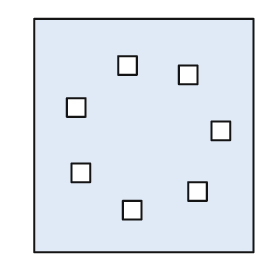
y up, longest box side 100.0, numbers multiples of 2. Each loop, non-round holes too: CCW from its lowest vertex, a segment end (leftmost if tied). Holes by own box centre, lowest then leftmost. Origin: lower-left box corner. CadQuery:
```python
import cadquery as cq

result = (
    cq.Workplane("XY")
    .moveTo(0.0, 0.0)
    .lineTo(94.0, 0.0)
    .lineTo(94.0, 100.0)
    .lineTo(0.0, 100.0)
    .close()
    .moveTo(38.0, 14.0)
    .lineTo(46.0, 14.0)
    .lineTo(46.0, 22.0)
    .lineTo(38.0, 22.0)
    .close()
    .moveTo(66.0, 22.0)
    .lineTo(74.0, 22.0)
    .lineTo(74.0, 30.0)
    .lineTo(66.0, 30.0)
    .close()
    .moveTo(16.0, 30.0)
    .lineTo(24.0, 30.0)
    .lineTo(24.0, 38.0)
    .lineTo(16.0, 38.0)
    .close()
    .moveTo(76.0, 48.0)
    .lineTo(84.0, 48.0)
    .lineTo(84.0, 56.0)
    .lineTo(76.0, 56.0)
    .close()
    .moveTo(14.0, 58.0)
    .lineTo(22.0, 58.0)
    .lineTo(22.0, 66.0)
    .lineTo(14.0, 66.0)
    .close()
    .moveTo(62.0, 72.0)
    .lineTo(70.0, 72.0)
    .lineTo(70.0, 80.0)
    .lineTo(62.0, 80.0)
    .close()
    .moveTo(36.0, 76.0)
    .lineTo(44.0, 76.0)
    .lineTo(44.0, 84.0)
    .lineTo(36.0, 84.0)
    .close()
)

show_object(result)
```